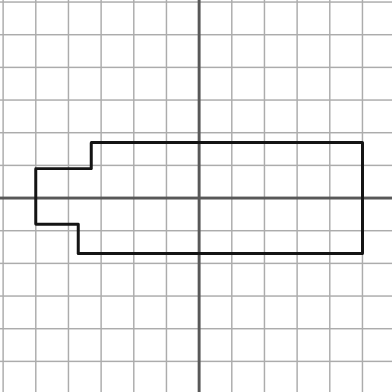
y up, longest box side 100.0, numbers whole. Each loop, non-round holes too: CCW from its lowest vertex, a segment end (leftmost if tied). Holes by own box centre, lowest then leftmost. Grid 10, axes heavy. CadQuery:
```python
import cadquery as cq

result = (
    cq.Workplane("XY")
    .moveTo(-37.0, -17.0)
    .lineTo(50.0, -17.0)
    .lineTo(50.0, 17.0)
    .lineTo(-33.0, 17.0)
    .lineTo(-33.0, 9.0)
    .lineTo(-50.0, 9.0)
    .lineTo(-50.0, -8.0)
    .lineTo(-37.0, -8.0)
    .close()
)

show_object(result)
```